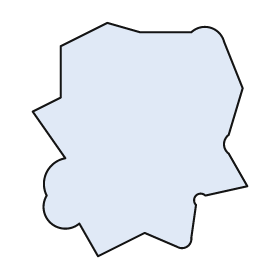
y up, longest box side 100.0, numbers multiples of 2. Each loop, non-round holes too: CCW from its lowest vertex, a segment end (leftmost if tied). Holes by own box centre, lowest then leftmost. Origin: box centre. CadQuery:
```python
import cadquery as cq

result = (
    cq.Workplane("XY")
    .moveTo(-18.0, -50.0)
    .lineTo(2.0, -40.0)
    .lineTo(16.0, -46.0)
    .threePointArc((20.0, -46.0), (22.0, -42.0))
    .lineTo(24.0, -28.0)
    .threePointArc((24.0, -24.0), (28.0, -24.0))
    .lineTo(46.0, -20.0)
    .lineTo(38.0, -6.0)
    .threePointArc((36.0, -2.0), (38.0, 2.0))
    .lineTo(44.0, 22.0)
    .lineTo(36.0, 42.0)
    .threePointArc((30.0, 48.0), (22.0, 46.0))
    .lineTo(0.0, 46.0)
    .lineTo(-14.0, 50.0)
    .lineTo(-34.0, 40.0)
    .lineTo(-34.0, 18.0)
    .lineTo(-46.0, 12.0)
    .lineTo(-32.0, -8.0)
    .threePointArc((-40.0, -14.0), (-40.0, -24.0))
    .threePointArc((-38.0, -36.0), (-26.0, -36.0))
    .close()
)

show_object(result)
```